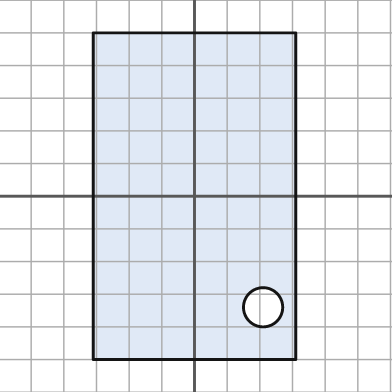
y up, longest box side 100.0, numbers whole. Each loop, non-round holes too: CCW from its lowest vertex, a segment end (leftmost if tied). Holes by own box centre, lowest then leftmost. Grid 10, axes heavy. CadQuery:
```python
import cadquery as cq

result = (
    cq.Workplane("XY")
    .moveTo(-31.0, -50.0)
    .lineTo(31.0, -50.0)
    .lineTo(31.0, 50.0)
    .lineTo(-31.0, 50.0)
    .close()
    .moveTo(21.0, -34.0)
    .circle(6.0)
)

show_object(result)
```